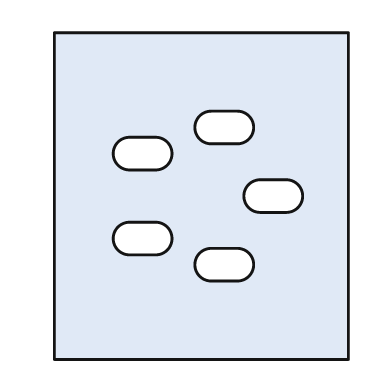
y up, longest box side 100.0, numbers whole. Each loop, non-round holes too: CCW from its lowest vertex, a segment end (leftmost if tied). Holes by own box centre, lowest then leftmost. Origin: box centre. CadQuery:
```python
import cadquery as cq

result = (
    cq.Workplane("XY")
    .moveTo(-45.0, -50.0)
    .lineTo(45.0, -50.0)
    .lineTo(45.0, 50.0)
    .lineTo(-45.0, 50.0)
    .close()
    .moveTo(3.0, -26.0)
    .lineTo(11.0, -26.0)
    .threePointArc((16.0, -21.0), (11.0, -16.0))
    .lineTo(3.0, -16.0)
    .threePointArc((-2.0, -21.0), (3.0, -26.0))
    .close()
    .moveTo(-22.0, -18.0)
    .lineTo(-14.0, -18.0)
    .threePointArc((-9.0, -13.0), (-14.0, -8.0))
    .lineTo(-22.0, -8.0)
    .threePointArc((-27.0, -13.0), (-22.0, -18.0))
    .close()
    .moveTo(18.0, -5.0)
    .lineTo(26.0, -5.0)
    .threePointArc((31.0, 0.0), (26.0, 5.0))
    .lineTo(18.0, 5.0)
    .threePointArc((13.0, 0.0), (18.0, -5.0))
    .close()
    .moveTo(-22.0, 8.0)
    .lineTo(-14.0, 8.0)
    .threePointArc((-9.0, 13.0), (-14.0, 18.0))
    .lineTo(-22.0, 18.0)
    .threePointArc((-27.0, 13.0), (-22.0, 8.0))
    .close()
    .moveTo(3.0, 16.0)
    .lineTo(11.0, 16.0)
    .threePointArc((16.0, 21.0), (11.0, 26.0))
    .lineTo(3.0, 26.0)
    .threePointArc((-2.0, 21.0), (3.0, 16.0))
    .close()
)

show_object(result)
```